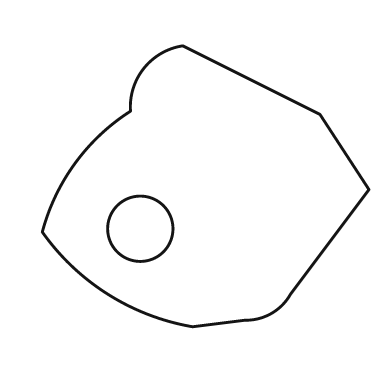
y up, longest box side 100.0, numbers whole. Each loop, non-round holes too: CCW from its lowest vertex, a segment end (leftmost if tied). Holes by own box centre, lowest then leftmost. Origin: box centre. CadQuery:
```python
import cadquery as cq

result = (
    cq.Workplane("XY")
    .moveTo(-4.0, -43.0)
    .lineTo(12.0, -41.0)
    .threePointArc((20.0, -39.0), (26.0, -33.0))
    .lineTo(50.0, -1.0)
    .lineTo(35.0, 22.0)
    .lineTo(-7.0, 43.0)
    .threePointArc((-19.0, 36.0), (-23.0, 23.0))
    .threePointArc((-40.0, 7.0), (-50.0, -14.0))
    .threePointArc((-30.0, -33.0), (-4.0, -43.0))
    .close()
    .moveTo(-20.0, -13.0)
    .circle(10.0)
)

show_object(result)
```